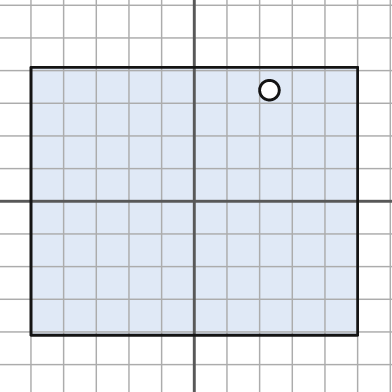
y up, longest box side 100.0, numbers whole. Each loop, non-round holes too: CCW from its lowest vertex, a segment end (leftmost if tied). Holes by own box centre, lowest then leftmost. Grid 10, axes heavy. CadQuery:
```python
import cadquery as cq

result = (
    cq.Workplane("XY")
    .moveTo(-50.0, -41.0)
    .lineTo(50.0, -41.0)
    .lineTo(50.0, 41.0)
    .lineTo(-50.0, 41.0)
    .close()
    .moveTo(23.0, 34.0)
    .circle(3.0)
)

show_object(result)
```